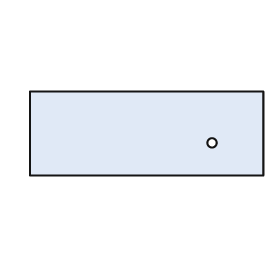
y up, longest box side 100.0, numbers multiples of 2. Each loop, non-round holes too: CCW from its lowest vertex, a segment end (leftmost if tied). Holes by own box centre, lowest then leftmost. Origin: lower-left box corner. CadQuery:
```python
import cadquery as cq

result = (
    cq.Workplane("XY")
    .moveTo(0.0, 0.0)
    .lineTo(100.0, 0.0)
    .lineTo(100.0, 36.0)
    .lineTo(0.0, 36.0)
    .close()
    .moveTo(78.0, 14.0)
    .circle(2.0)
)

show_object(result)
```